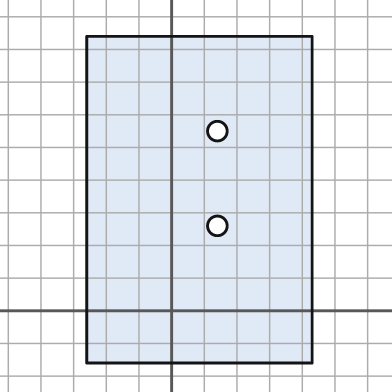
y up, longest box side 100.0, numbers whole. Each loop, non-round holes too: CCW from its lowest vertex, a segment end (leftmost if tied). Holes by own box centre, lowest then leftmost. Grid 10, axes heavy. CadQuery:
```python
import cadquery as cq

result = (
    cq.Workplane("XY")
    .moveTo(-26.0, -16.0)
    .lineTo(43.0, -16.0)
    .lineTo(43.0, 84.0)
    .lineTo(-26.0, 84.0)
    .close()
    .moveTo(14.0, 26.0)
    .circle(3.0)
    .moveTo(14.0, 55.0)
    .circle(3.0)
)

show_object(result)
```